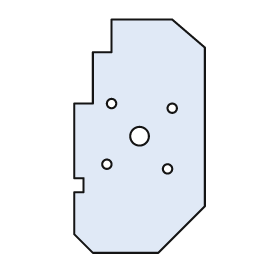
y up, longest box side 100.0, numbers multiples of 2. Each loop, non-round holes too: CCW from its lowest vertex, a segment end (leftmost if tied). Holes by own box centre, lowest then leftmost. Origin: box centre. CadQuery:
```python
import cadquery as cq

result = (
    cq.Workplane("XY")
    .moveTo(-20.0, -50.0)
    .lineTo(8.0, -50.0)
    .lineTo(28.0, -30.0)
    .lineTo(28.0, 38.0)
    .lineTo(14.0, 50.0)
    .lineTo(-12.0, 50.0)
    .lineTo(-12.0, 36.0)
    .lineTo(-20.0, 36.0)
    .lineTo(-20.0, 14.0)
    .lineTo(-28.0, 14.0)
    .lineTo(-28.0, -18.0)
    .lineTo(-24.0, -18.0)
    .lineTo(-24.0, -24.0)
    .lineTo(-28.0, -24.0)
    .lineTo(-28.0, -42.0)
    .close()
    .moveTo(12.0, -14.0)
    .circle(2.0)
    .moveTo(-14.0, -12.0)
    .circle(2.0)
    .moveTo(0.0, 0.0)
    .circle(4.0)
    .moveTo(14.0, 12.0)
    .circle(2.0)
    .moveTo(-12.0, 14.0)
    .circle(2.0)
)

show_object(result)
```